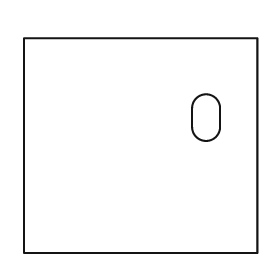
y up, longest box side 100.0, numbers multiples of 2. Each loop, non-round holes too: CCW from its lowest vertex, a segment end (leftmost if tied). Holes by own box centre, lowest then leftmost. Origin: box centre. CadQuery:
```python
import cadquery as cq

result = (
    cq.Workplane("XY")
    .moveTo(-50.0, -46.0)
    .lineTo(50.0, -46.0)
    .lineTo(50.0, 46.0)
    .lineTo(-50.0, 46.0)
    .close()
    .moveTo(22.0, 8.0)
    .threePointArc((28.0, 2.0), (34.0, 8.0))
    .lineTo(34.0, 16.0)
    .threePointArc((28.0, 22.0), (22.0, 16.0))
    .close()
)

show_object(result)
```